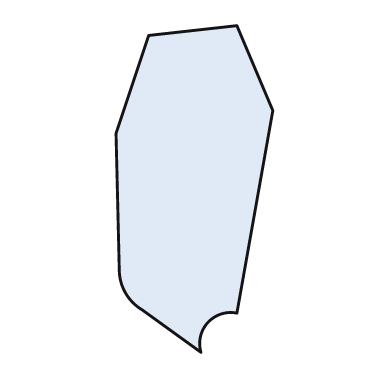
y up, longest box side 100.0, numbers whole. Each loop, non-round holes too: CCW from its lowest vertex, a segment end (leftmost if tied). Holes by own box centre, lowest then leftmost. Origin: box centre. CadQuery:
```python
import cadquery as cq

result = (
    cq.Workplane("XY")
    .moveTo(2.0, -50.0)
    .threePointArc((4.0, -41.0), (13.0, -38.0))
    .lineTo(24.0, 24.0)
    .lineTo(13.0, 50.0)
    .lineTo(-14.0, 47.0)
    .lineTo(-24.0, 17.0)
    .lineTo(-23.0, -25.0)
    .threePointArc((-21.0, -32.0), (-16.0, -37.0))
    .close()
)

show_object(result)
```